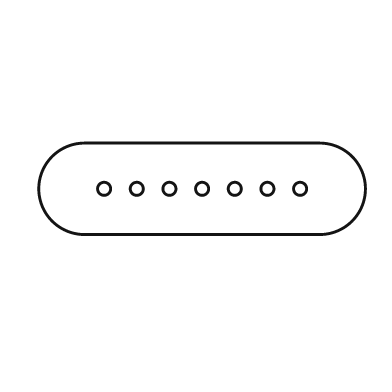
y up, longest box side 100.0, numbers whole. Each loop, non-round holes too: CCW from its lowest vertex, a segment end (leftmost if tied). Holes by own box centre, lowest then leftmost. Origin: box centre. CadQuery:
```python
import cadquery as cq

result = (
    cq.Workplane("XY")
    .moveTo(-36.0, -14.0)
    .lineTo(36.0, -14.0)
    .threePointArc((50.0, 0.0), (36.0, 14.0))
    .lineTo(-36.0, 14.0)
    .threePointArc((-50.0, 0.0), (-36.0, -14.0))
    .close()
    .moveTo(-30.0, 0.0)
    .circle(2.0)
    .moveTo(-20.0, 0.0)
    .circle(2.0)
    .moveTo(-10.0, 0.0)
    .circle(2.0)
    .moveTo(0.0, 0.0)
    .circle(2.0)
    .moveTo(10.0, 0.0)
    .circle(2.0)
    .moveTo(20.0, 0.0)
    .circle(2.0)
    .moveTo(30.0, 0.0)
    .circle(2.0)
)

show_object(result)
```